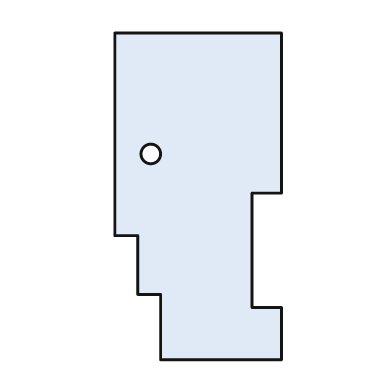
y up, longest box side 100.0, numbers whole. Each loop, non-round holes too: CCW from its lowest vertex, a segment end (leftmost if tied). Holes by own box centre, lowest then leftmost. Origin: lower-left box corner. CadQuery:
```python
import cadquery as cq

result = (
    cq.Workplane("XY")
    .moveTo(14.0, 0.0)
    .lineTo(51.0, 0.0)
    .lineTo(51.0, 16.0)
    .lineTo(42.0, 16.0)
    .lineTo(42.0, 51.0)
    .lineTo(51.0, 51.0)
    .lineTo(51.0, 100.0)
    .lineTo(0.0, 100.0)
    .lineTo(0.0, 38.0)
    .lineTo(7.0, 38.0)
    .lineTo(7.0, 20.0)
    .lineTo(14.0, 20.0)
    .close()
    .moveTo(11.0, 63.0)
    .circle(3.0)
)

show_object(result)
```